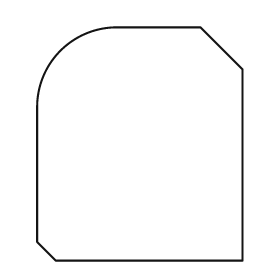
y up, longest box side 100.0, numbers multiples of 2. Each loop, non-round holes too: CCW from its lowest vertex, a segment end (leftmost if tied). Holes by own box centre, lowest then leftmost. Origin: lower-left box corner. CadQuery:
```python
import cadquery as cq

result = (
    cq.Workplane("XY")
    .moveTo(8.0, 0.0)
    .lineTo(88.0, 0.0)
    .lineTo(88.0, 82.0)
    .lineTo(70.0, 100.0)
    .lineTo(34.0, 100.0)
    .threePointArc((10.0, 90.0), (0.0, 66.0))
    .lineTo(0.0, 8.0)
    .close()
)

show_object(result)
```